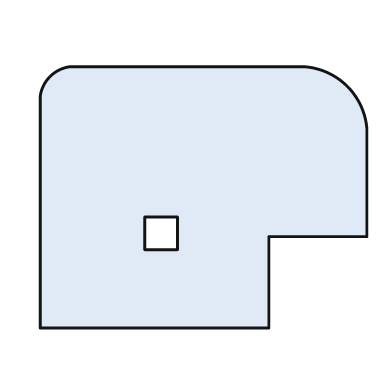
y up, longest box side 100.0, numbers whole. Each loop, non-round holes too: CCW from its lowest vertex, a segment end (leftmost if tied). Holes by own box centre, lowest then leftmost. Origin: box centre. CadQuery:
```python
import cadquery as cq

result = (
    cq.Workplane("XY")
    .moveTo(-50.0, -40.0)
    .lineTo(20.0, -40.0)
    .lineTo(20.0, -12.0)
    .lineTo(50.0, -12.0)
    .lineTo(50.0, 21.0)
    .threePointArc((44.0, 34.0), (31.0, 40.0))
    .lineTo(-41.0, 40.0)
    .threePointArc((-47.0, 37.0), (-50.0, 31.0))
    .close()
    .moveTo(-18.0, -16.0)
    .lineTo(-8.0, -16.0)
    .lineTo(-8.0, -6.0)
    .lineTo(-18.0, -6.0)
    .close()
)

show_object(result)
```